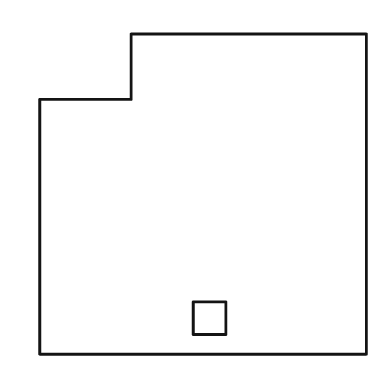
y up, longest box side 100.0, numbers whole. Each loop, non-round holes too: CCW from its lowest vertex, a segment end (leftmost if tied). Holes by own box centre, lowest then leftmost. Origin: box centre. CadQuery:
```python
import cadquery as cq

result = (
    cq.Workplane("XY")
    .moveTo(-50.0, -49.0)
    .lineTo(50.0, -49.0)
    .lineTo(50.0, 49.0)
    .lineTo(-22.0, 49.0)
    .lineTo(-22.0, 29.0)
    .lineTo(-50.0, 29.0)
    .close()
    .moveTo(-3.0, -43.0)
    .lineTo(7.0, -43.0)
    .lineTo(7.0, -33.0)
    .lineTo(-3.0, -33.0)
    .close()
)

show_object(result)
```